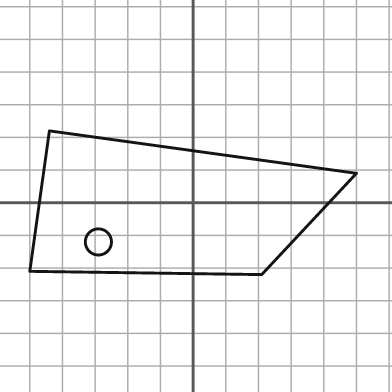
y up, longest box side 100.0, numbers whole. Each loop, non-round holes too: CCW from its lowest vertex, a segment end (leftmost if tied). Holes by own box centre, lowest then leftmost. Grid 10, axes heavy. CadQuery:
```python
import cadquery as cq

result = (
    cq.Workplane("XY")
    .moveTo(21.0, -22.0)
    .lineTo(50.0, 9.0)
    .lineTo(-44.0, 22.0)
    .lineTo(-50.0, -21.0)
    .close()
    .moveTo(-29.0, -12.0)
    .circle(4.0)
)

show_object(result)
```